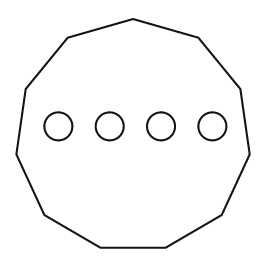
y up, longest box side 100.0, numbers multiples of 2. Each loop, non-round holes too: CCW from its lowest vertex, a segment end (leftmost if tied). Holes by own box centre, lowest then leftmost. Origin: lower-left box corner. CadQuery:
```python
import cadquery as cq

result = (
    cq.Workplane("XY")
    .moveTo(36.0, 0.0)
    .lineTo(64.0, 0.0)
    .lineTo(88.0, 14.0)
    .lineTo(100.0, 40.0)
    .lineTo(96.0, 68.0)
    .lineTo(78.0, 90.0)
    .lineTo(50.0, 98.0)
    .lineTo(22.0, 90.0)
    .lineTo(4.0, 68.0)
    .lineTo(0.0, 40.0)
    .lineTo(12.0, 14.0)
    .close()
    .moveTo(18.0, 52.0)
    .circle(6.0)
    .moveTo(40.0, 52.0)
    .circle(6.0)
    .moveTo(62.0, 52.0)
    .circle(6.0)
    .moveTo(84.0, 52.0)
    .circle(6.0)
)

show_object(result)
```